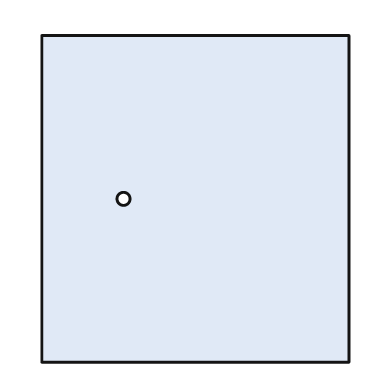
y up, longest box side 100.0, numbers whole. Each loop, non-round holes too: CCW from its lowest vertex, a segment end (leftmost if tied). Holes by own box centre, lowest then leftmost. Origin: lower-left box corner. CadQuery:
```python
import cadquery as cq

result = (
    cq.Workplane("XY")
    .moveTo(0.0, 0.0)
    .lineTo(94.0, 0.0)
    .lineTo(94.0, 100.0)
    .lineTo(0.0, 100.0)
    .close()
    .moveTo(25.0, 50.0)
    .circle(2.0)
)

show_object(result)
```